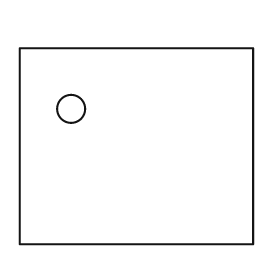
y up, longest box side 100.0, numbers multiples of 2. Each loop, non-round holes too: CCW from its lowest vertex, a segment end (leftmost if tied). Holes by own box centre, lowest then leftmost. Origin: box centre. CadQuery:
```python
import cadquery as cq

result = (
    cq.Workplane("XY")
    .moveTo(-50.0, -42.0)
    .lineTo(50.0, -42.0)
    .lineTo(50.0, 42.0)
    .lineTo(-50.0, 42.0)
    .close()
    .moveTo(-28.0, 16.0)
    .circle(6.0)
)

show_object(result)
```